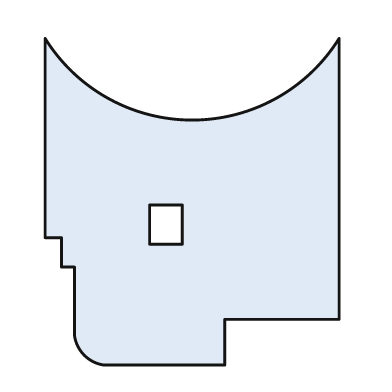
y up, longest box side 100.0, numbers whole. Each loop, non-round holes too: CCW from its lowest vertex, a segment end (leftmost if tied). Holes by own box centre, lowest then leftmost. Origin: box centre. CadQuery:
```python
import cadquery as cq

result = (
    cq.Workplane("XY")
    .moveTo(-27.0, -50.0)
    .lineTo(10.0, -50.0)
    .lineTo(10.0, -36.0)
    .lineTo(45.0, -36.0)
    .lineTo(45.0, 50.0)
    .threePointArc((0.0, 25.0), (-45.0, 50.0))
    .lineTo(-45.0, -11.0)
    .lineTo(-40.0, -11.0)
    .lineTo(-40.0, -20.0)
    .lineTo(-36.0, -20.0)
    .lineTo(-36.0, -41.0)
    .threePointArc((-33.0, -47.0), (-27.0, -50.0))
    .close()
    .moveTo(-13.0, -13.0)
    .lineTo(-3.0, -13.0)
    .lineTo(-3.0, -1.0)
    .lineTo(-13.0, -1.0)
    .close()
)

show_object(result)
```